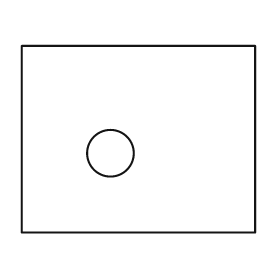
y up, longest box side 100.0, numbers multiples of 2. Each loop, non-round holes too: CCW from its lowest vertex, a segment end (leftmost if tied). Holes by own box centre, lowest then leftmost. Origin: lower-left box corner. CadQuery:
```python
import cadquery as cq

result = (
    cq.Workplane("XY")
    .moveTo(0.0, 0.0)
    .lineTo(100.0, 0.0)
    .lineTo(100.0, 80.0)
    .lineTo(0.0, 80.0)
    .close()
    .moveTo(38.0, 34.0)
    .circle(10.0)
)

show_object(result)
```